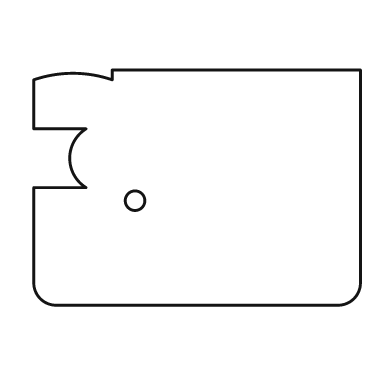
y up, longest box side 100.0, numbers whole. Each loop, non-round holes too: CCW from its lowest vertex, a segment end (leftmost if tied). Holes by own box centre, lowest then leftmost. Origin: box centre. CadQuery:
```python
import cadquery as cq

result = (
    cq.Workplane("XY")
    .moveTo(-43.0, -36.0)
    .lineTo(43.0, -36.0)
    .threePointArc((48.0, -34.0), (50.0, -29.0))
    .lineTo(50.0, 36.0)
    .lineTo(-26.0, 36.0)
    .lineTo(-26.0, 33.0)
    .threePointArc((-38.0, 35.0), (-50.0, 33.0))
    .lineTo(-50.0, 18.0)
    .lineTo(-34.0, 18.0)
    .threePointArc((-39.0, 9.0), (-34.0, 0.0))
    .lineTo(-50.0, 0.0)
    .lineTo(-50.0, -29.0)
    .threePointArc((-48.0, -34.0), (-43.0, -36.0))
    .close()
    .moveTo(-19.0, -4.0)
    .circle(3.0)
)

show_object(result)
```